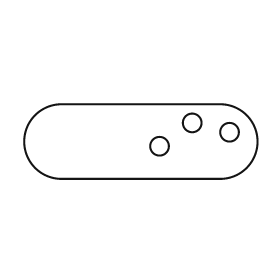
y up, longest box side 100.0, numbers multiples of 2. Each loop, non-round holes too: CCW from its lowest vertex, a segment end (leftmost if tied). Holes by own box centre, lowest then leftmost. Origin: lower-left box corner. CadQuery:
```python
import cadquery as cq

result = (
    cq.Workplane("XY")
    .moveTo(16.0, 0.0)
    .lineTo(84.0, 0.0)
    .threePointArc((100.0, 16.0), (84.0, 32.0))
    .lineTo(16.0, 32.0)
    .threePointArc((0.0, 16.0), (16.0, 0.0))
    .close()
    .moveTo(58.0, 14.0)
    .circle(4.0)
    .moveTo(88.0, 20.0)
    .circle(4.0)
    .moveTo(72.0, 24.0)
    .circle(4.0)
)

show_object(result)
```